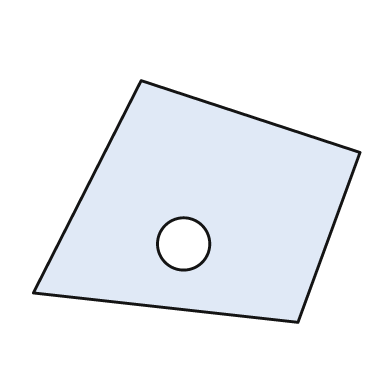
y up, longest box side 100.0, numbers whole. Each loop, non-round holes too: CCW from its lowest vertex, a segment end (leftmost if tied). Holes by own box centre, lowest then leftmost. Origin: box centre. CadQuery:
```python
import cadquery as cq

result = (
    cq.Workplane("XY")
    .moveTo(31.0, -37.0)
    .lineTo(50.0, 15.0)
    .lineTo(-17.0, 37.0)
    .lineTo(-50.0, -28.0)
    .close()
    .moveTo(-4.0, -13.0)
    .circle(8.0)
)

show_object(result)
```